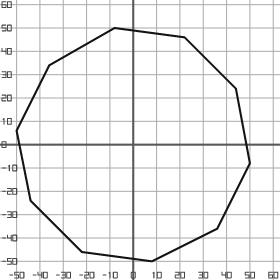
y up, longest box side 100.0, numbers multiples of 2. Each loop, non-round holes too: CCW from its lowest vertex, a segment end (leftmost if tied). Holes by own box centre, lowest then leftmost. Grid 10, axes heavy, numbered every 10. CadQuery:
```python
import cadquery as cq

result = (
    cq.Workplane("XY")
    .moveTo(8.0, -50.0)
    .lineTo(36.0, -36.0)
    .lineTo(50.0, -8.0)
    .lineTo(44.0, 24.0)
    .lineTo(22.0, 46.0)
    .lineTo(-8.0, 50.0)
    .lineTo(-36.0, 34.0)
    .lineTo(-50.0, 6.0)
    .lineTo(-44.0, -24.0)
    .lineTo(-22.0, -46.0)
    .close()
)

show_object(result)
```